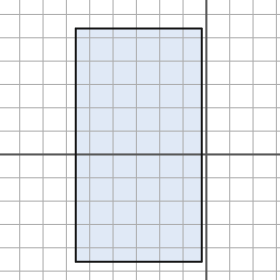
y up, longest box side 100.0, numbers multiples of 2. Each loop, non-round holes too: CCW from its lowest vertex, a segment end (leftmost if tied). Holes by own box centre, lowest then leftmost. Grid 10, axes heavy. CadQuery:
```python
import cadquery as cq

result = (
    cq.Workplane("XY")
    .moveTo(-56.0, -46.0)
    .lineTo(-2.0, -46.0)
    .lineTo(-2.0, 54.0)
    .lineTo(-56.0, 54.0)
    .close()
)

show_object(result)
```